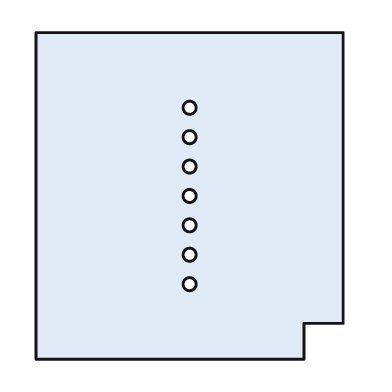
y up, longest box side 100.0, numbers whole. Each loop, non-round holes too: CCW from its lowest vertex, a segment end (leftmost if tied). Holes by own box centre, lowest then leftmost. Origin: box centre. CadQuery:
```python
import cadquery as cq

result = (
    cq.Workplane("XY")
    .moveTo(-47.0, -50.0)
    .lineTo(35.0, -50.0)
    .lineTo(35.0, -39.0)
    .lineTo(47.0, -39.0)
    .lineTo(47.0, 50.0)
    .lineTo(-47.0, 50.0)
    .close()
    .moveTo(0.0, -27.0)
    .circle(2.0)
    .moveTo(0.0, -18.0)
    .circle(2.0)
    .moveTo(0.0, -9.0)
    .circle(2.0)
    .moveTo(0.0, 0.0)
    .circle(2.0)
    .moveTo(0.0, 9.0)
    .circle(2.0)
    .moveTo(0.0, 18.0)
    .circle(2.0)
    .moveTo(0.0, 27.0)
    .circle(2.0)
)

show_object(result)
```